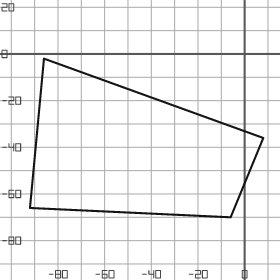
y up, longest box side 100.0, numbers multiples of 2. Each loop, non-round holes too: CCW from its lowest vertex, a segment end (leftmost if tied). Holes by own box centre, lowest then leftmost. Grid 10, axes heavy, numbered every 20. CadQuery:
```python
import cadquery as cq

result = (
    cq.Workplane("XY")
    .moveTo(-6.0, -70.0)
    .lineTo(8.0, -36.0)
    .lineTo(-86.0, -2.0)
    .lineTo(-92.0, -66.0)
    .close()
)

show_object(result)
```